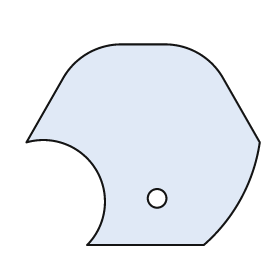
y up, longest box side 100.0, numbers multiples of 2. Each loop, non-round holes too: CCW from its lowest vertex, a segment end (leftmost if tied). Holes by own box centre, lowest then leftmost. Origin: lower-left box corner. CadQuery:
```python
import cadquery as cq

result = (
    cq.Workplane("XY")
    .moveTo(26.0, 0.0)
    .lineTo(76.0, 0.0)
    .threePointArc((92.0, 20.0), (100.0, 44.0))
    .lineTo(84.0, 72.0)
    .threePointArc((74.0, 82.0), (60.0, 86.0))
    .lineTo(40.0, 86.0)
    .threePointArc((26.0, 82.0), (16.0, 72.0))
    .lineTo(0.0, 44.0)
    .threePointArc((30.0, 32.0), (26.0, 0.0))
    .close()
    .moveTo(56.0, 20.0)
    .circle(4.0)
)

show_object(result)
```